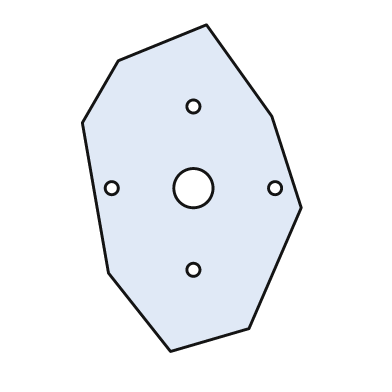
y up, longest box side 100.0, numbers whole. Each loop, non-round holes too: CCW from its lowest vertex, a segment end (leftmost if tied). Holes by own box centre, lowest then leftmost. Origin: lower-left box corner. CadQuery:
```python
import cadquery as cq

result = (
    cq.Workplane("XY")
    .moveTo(27.0, 0.0)
    .lineTo(51.0, 7.0)
    .lineTo(67.0, 44.0)
    .lineTo(58.0, 72.0)
    .lineTo(38.0, 100.0)
    .lineTo(11.0, 89.0)
    .lineTo(0.0, 70.0)
    .lineTo(8.0, 24.0)
    .close()
    .moveTo(34.0, 25.0)
    .circle(2.0)
    .moveTo(9.0, 50.0)
    .circle(2.0)
    .moveTo(34.0, 50.0)
    .circle(6.0)
    .moveTo(59.0, 50.0)
    .circle(2.0)
    .moveTo(34.0, 75.0)
    .circle(2.0)
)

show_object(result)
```